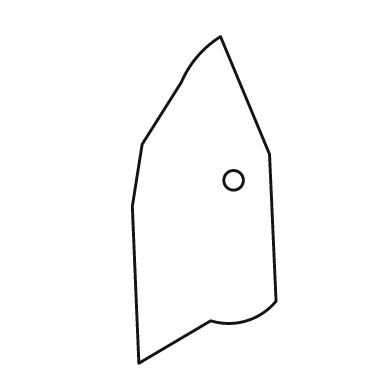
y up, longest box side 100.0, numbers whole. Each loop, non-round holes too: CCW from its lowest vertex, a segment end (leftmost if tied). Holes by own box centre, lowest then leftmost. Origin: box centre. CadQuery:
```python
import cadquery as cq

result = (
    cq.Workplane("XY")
    .moveTo(-20.0, -50.0)
    .lineTo(2.0, -37.0)
    .threePointArc((13.0, -37.0), (22.0, -31.0))
    .lineTo(20.0, 14.0)
    .lineTo(5.0, 50.0)
    .threePointArc((-2.0, 44.0), (-7.0, 36.0))
    .lineTo(-19.0, 17.0)
    .lineTo(-22.0, -2.0)
    .close()
    .moveTo(9.0, 6.0)
    .circle(3.0)
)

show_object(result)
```